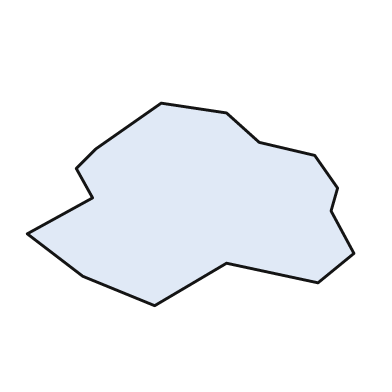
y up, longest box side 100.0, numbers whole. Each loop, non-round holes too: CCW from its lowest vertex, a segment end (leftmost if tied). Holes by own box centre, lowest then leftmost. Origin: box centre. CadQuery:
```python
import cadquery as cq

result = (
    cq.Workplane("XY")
    .moveTo(-11.0, -31.0)
    .lineTo(11.0, -18.0)
    .lineTo(39.0, -24.0)
    .lineTo(50.0, -15.0)
    .lineTo(43.0, -2.0)
    .lineTo(45.0, 5.0)
    .lineTo(38.0, 15.0)
    .lineTo(21.0, 19.0)
    .lineTo(11.0, 28.0)
    .lineTo(-9.0, 31.0)
    .lineTo(-29.0, 17.0)
    .lineTo(-35.0, 11.0)
    .lineTo(-30.0, 2.0)
    .lineTo(-50.0, -9.0)
    .lineTo(-33.0, -22.0)
    .close()
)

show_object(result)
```